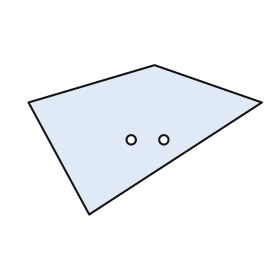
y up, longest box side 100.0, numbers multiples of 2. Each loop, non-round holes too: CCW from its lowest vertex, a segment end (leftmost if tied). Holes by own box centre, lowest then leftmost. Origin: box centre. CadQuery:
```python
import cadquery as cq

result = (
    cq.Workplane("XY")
    .moveTo(-24.0, -32.0)
    .lineTo(50.0, 16.0)
    .lineTo(4.0, 32.0)
    .lineTo(-50.0, 16.0)
    .close()
    .moveTo(-6.0, 0.0)
    .circle(2.0)
    .moveTo(8.0, 0.0)
    .circle(2.0)
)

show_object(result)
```